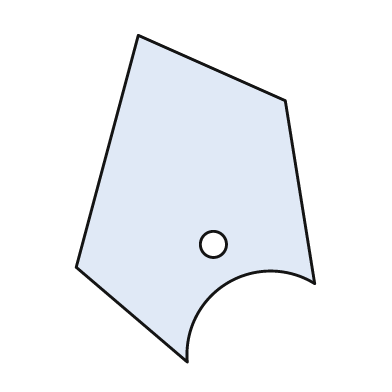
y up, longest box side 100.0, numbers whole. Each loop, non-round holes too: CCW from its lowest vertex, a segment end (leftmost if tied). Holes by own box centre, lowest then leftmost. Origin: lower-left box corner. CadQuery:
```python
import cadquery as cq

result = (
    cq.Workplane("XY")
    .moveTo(34.0, 0.0)
    .threePointArc((46.0, 24.0), (73.0, 24.0))
    .lineTo(64.0, 80.0)
    .lineTo(19.0, 100.0)
    .lineTo(0.0, 29.0)
    .close()
    .moveTo(42.0, 36.0)
    .circle(4.0)
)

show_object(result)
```